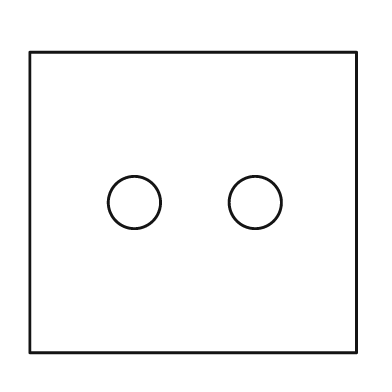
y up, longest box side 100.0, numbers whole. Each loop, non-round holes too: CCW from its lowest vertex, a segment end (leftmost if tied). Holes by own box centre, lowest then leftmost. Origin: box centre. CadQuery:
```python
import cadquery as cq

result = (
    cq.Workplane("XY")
    .moveTo(-50.0, -46.0)
    .lineTo(50.0, -46.0)
    .lineTo(50.0, 46.0)
    .lineTo(-50.0, 46.0)
    .close()
    .moveTo(-18.0, 0.0)
    .circle(8.0)
    .moveTo(19.0, 0.0)
    .circle(8.0)
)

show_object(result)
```